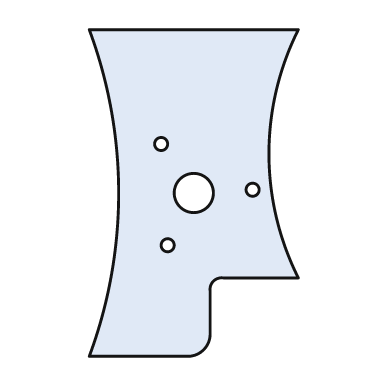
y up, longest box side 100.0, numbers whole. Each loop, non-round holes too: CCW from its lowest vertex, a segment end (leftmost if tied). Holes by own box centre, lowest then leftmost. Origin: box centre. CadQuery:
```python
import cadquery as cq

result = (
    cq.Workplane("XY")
    .moveTo(-32.0, -50.0)
    .lineTo(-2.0, -50.0)
    .threePointArc((3.0, -48.0), (5.0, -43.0))
    .lineTo(5.0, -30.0)
    .threePointArc((6.0, -27.0), (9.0, -26.0))
    .lineTo(32.0, -26.0)
    .threePointArc((23.0, 12.0), (32.0, 50.0))
    .lineTo(-32.0, 50.0)
    .threePointArc((-23.0, 0.0), (-32.0, -50.0))
    .close()
    .moveTo(-8.0, -16.0)
    .circle(2.0)
    .moveTo(0.0, 0.0)
    .circle(6.0)
    .moveTo(18.0, 1.0)
    .circle(2.0)
    .moveTo(-10.0, 15.0)
    .circle(2.0)
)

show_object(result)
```